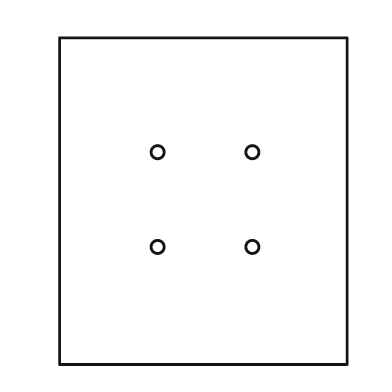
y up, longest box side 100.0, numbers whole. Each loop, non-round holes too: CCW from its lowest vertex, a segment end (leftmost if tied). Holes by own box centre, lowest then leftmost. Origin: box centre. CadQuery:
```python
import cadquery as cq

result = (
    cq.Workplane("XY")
    .moveTo(-44.0, -50.0)
    .lineTo(44.0, -50.0)
    .lineTo(44.0, 50.0)
    .lineTo(-44.0, 50.0)
    .close()
    .moveTo(-14.0, -14.0)
    .circle(2.0)
    .moveTo(15.0, -14.0)
    .circle(2.0)
    .moveTo(-14.0, 15.0)
    .circle(2.0)
    .moveTo(15.0, 15.0)
    .circle(2.0)
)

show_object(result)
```